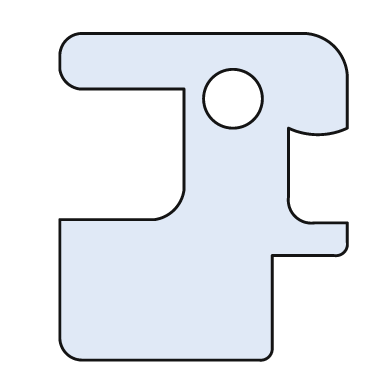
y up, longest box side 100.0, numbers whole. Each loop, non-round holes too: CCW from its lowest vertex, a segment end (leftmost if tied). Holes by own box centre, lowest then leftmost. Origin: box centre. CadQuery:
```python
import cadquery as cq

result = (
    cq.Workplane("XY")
    .moveTo(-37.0, -50.0)
    .lineTo(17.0, -50.0)
    .threePointArc((20.0, -49.0), (21.0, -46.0))
    .lineTo(21.0, -18.0)
    .lineTo(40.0, -18.0)
    .threePointArc((43.0, -17.0), (44.0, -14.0))
    .lineTo(44.0, -8.0)
    .lineTo(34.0, -8.0)
    .threePointArc((28.0, -6.0), (26.0, 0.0))
    .lineTo(26.0, 21.0)
    .threePointArc((35.0, 19.0), (44.0, 21.0))
    .lineTo(44.0, 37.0)
    .threePointArc((40.0, 46.0), (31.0, 50.0))
    .lineTo(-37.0, 50.0)
    .threePointArc((-42.0, 48.0), (-44.0, 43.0))
    .lineTo(-44.0, 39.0)
    .threePointArc((-42.0, 35.0), (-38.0, 33.0))
    .lineTo(-6.0, 33.0)
    .lineTo(-6.0, 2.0)
    .threePointArc((-9.0, -4.0), (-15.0, -7.0))
    .lineTo(-44.0, -7.0)
    .lineTo(-44.0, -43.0)
    .threePointArc((-42.0, -48.0), (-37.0, -50.0))
    .close()
    .moveTo(9.0, 30.0)
    .circle(9.0)
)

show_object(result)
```